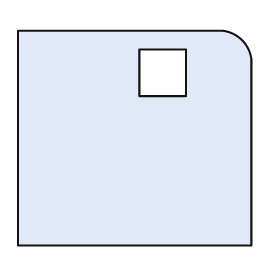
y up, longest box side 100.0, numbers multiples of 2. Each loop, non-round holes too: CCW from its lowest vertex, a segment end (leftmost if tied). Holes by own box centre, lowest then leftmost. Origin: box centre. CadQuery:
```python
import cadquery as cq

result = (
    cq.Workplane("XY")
    .moveTo(-50.0, -46.0)
    .lineTo(50.0, -46.0)
    .lineTo(50.0, 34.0)
    .threePointArc((46.0, 42.0), (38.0, 46.0))
    .lineTo(-50.0, 46.0)
    .close()
    .moveTo(2.0, 18.0)
    .lineTo(22.0, 18.0)
    .lineTo(22.0, 38.0)
    .lineTo(2.0, 38.0)
    .close()
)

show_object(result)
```